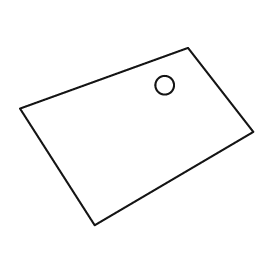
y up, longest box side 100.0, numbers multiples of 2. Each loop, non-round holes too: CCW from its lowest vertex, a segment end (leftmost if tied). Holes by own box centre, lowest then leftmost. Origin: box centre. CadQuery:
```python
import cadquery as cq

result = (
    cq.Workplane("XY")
    .moveTo(-18.0, -38.0)
    .lineTo(50.0, 2.0)
    .lineTo(22.0, 38.0)
    .lineTo(-50.0, 12.0)
    .close()
    .moveTo(12.0, 22.0)
    .circle(4.0)
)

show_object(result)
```